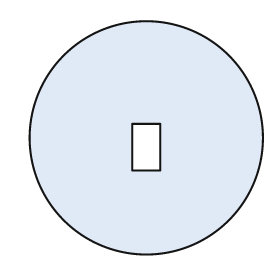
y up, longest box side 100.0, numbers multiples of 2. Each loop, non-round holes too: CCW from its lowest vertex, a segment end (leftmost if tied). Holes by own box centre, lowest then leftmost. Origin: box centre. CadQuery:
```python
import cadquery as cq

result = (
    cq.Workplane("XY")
    .moveTo(0.0, 0.0)
    .circle(50.0)
    .moveTo(-6.0, -14.0)
    .lineTo(6.0, -14.0)
    .lineTo(6.0, 6.0)
    .lineTo(-6.0, 6.0)
    .close()
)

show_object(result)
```